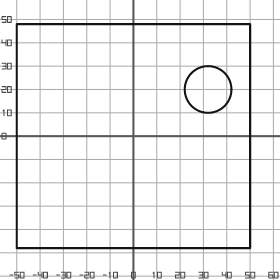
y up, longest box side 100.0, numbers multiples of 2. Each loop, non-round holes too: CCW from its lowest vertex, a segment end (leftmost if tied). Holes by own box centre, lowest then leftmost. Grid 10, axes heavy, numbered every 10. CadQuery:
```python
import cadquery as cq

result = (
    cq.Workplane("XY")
    .moveTo(-50.0, -48.0)
    .lineTo(50.0, -48.0)
    .lineTo(50.0, 48.0)
    .lineTo(-50.0, 48.0)
    .close()
    .moveTo(32.0, 20.0)
    .circle(10.0)
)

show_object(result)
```